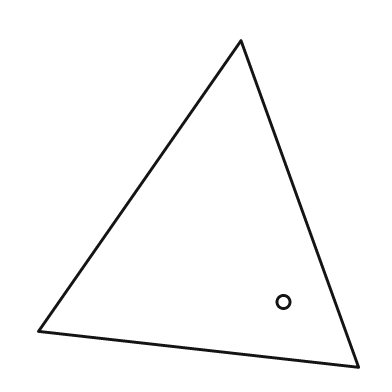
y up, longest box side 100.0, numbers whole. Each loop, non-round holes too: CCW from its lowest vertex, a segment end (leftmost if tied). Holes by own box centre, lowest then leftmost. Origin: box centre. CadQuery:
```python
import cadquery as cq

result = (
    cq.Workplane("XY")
    .moveTo(49.0, -50.0)
    .lineTo(13.0, 50.0)
    .lineTo(-49.0, -39.0)
    .close()
    .moveTo(26.0, -30.0)
    .circle(2.0)
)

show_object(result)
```